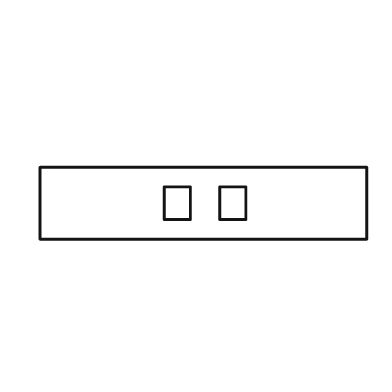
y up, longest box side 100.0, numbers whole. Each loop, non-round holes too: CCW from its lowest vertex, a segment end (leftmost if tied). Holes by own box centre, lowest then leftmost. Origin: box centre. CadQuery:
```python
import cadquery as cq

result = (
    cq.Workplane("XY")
    .moveTo(-50.0, -11.0)
    .lineTo(50.0, -11.0)
    .lineTo(50.0, 11.0)
    .lineTo(-50.0, 11.0)
    .close()
    .moveTo(-12.0, -5.0)
    .lineTo(-4.0, -5.0)
    .lineTo(-4.0, 5.0)
    .lineTo(-12.0, 5.0)
    .close()
    .moveTo(5.0, -5.0)
    .lineTo(13.0, -5.0)
    .lineTo(13.0, 5.0)
    .lineTo(5.0, 5.0)
    .close()
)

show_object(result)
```